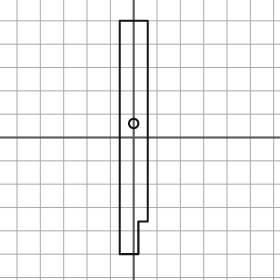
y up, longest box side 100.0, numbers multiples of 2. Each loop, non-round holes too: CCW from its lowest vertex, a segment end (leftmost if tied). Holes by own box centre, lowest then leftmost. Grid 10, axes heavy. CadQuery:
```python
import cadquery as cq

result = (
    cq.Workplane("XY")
    .moveTo(-6.0, -50.0)
    .lineTo(2.0, -50.0)
    .lineTo(2.0, -36.0)
    .lineTo(6.0, -36.0)
    .lineTo(6.0, 50.0)
    .lineTo(-6.0, 50.0)
    .close()
    .moveTo(0.0, 6.0)
    .circle(2.0)
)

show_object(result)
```